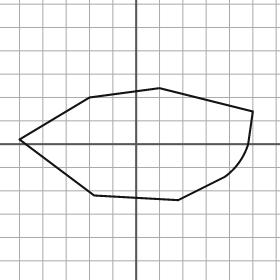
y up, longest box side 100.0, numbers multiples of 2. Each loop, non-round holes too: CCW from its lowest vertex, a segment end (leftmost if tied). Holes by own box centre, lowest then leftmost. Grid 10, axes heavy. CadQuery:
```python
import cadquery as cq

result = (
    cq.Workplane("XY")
    .moveTo(18.0, -24.0)
    .lineTo(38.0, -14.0)
    .threePointArc((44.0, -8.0), (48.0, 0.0))
    .lineTo(50.0, 14.0)
    .lineTo(10.0, 24.0)
    .lineTo(-20.0, 20.0)
    .lineTo(-50.0, 2.0)
    .lineTo(-18.0, -22.0)
    .close()
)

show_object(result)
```